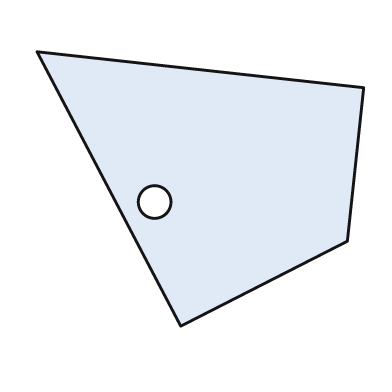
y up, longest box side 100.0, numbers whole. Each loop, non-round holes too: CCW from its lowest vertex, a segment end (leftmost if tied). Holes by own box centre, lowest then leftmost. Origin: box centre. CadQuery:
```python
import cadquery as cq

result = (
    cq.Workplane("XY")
    .moveTo(-6.0, -42.0)
    .lineTo(45.0, -16.0)
    .lineTo(50.0, 31.0)
    .lineTo(-50.0, 42.0)
    .close()
    .moveTo(-14.0, -4.0)
    .circle(5.0)
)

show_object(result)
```